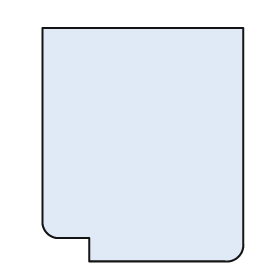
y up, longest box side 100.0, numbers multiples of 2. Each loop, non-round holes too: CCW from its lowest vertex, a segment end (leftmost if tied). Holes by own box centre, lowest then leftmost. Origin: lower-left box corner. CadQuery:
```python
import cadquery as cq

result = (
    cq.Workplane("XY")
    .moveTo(20.0, 0.0)
    .lineTo(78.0, 0.0)
    .threePointArc((84.0, 2.0), (86.0, 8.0))
    .lineTo(86.0, 100.0)
    .lineTo(0.0, 100.0)
    .lineTo(0.0, 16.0)
    .threePointArc((2.0, 12.0), (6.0, 10.0))
    .lineTo(20.0, 10.0)
    .close()
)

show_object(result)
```